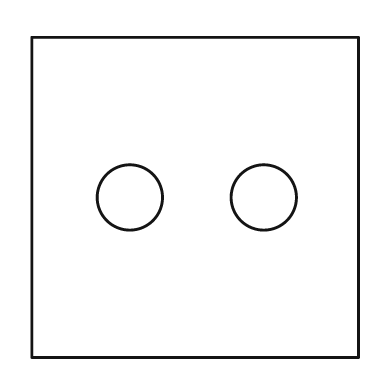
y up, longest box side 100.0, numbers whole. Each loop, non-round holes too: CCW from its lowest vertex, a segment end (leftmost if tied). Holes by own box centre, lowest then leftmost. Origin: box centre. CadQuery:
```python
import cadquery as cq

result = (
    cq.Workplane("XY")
    .moveTo(-50.0, -49.0)
    .lineTo(50.0, -49.0)
    .lineTo(50.0, 49.0)
    .lineTo(-50.0, 49.0)
    .close()
    .moveTo(-20.0, 0.0)
    .circle(10.0)
    .moveTo(21.0, 0.0)
    .circle(10.0)
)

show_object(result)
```